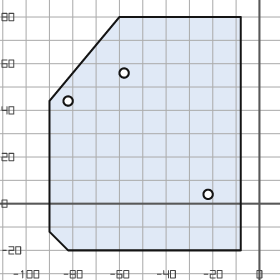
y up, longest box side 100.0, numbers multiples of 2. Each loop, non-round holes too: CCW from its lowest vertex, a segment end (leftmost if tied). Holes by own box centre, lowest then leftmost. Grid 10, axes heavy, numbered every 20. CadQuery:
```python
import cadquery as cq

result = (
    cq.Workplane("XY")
    .moveTo(-82.0, -20.0)
    .lineTo(-8.0, -20.0)
    .lineTo(-8.0, 80.0)
    .lineTo(-60.0, 80.0)
    .lineTo(-90.0, 44.0)
    .lineTo(-90.0, -12.0)
    .close()
    .moveTo(-22.0, 4.0)
    .circle(2.0)
    .moveTo(-82.0, 44.0)
    .circle(2.0)
    .moveTo(-58.0, 56.0)
    .circle(2.0)
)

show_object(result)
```